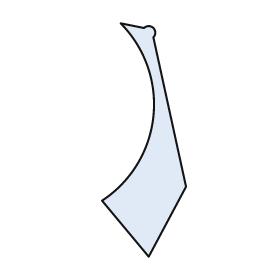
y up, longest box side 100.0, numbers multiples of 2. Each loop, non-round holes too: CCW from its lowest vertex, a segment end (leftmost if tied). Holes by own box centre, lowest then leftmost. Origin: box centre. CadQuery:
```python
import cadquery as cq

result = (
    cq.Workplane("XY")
    .moveTo(2.0, -50.0)
    .lineTo(18.0, -20.0)
    .lineTo(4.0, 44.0)
    .threePointArc((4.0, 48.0), (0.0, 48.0))
    .lineTo(-10.0, 50.0)
    .threePointArc((4.0, 10.0), (-18.0, -26.0))
    .close()
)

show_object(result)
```